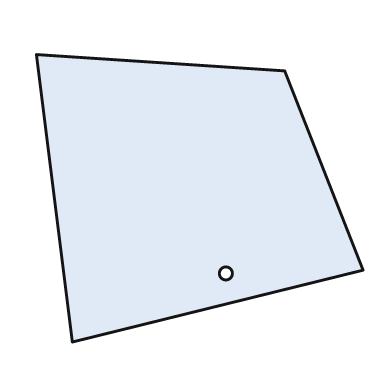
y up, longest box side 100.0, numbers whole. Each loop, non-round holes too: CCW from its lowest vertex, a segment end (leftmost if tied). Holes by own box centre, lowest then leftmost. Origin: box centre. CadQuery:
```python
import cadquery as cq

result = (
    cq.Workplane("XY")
    .moveTo(-39.0, -44.0)
    .lineTo(50.0, -22.0)
    .lineTo(26.0, 39.0)
    .lineTo(-50.0, 44.0)
    .close()
    .moveTo(8.0, -23.0)
    .circle(2.0)
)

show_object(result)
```